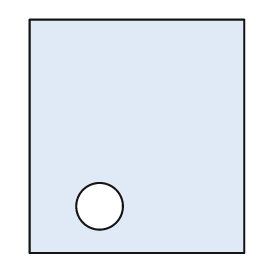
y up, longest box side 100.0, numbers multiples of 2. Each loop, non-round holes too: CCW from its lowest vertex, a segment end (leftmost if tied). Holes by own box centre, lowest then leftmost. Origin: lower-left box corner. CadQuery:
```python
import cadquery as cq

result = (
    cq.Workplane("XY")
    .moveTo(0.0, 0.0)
    .lineTo(92.0, 0.0)
    .lineTo(92.0, 100.0)
    .lineTo(0.0, 100.0)
    .close()
    .moveTo(30.0, 20.0)
    .circle(10.0)
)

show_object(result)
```